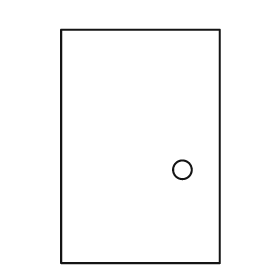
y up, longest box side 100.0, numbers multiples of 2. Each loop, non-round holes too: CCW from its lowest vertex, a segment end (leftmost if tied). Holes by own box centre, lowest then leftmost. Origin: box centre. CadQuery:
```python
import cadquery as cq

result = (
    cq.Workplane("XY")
    .moveTo(-34.0, -50.0)
    .lineTo(34.0, -50.0)
    .lineTo(34.0, 50.0)
    .lineTo(-34.0, 50.0)
    .close()
    .moveTo(18.0, -10.0)
    .circle(4.0)
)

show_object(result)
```